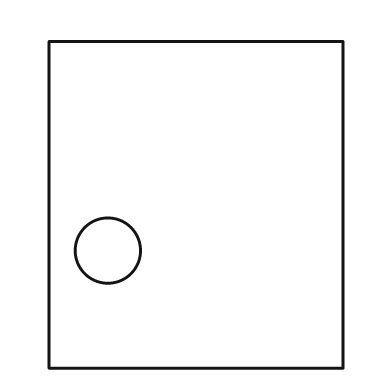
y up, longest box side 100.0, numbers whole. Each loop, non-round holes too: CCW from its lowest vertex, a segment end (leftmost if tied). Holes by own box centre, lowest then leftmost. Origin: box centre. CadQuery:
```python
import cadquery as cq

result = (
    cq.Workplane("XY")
    .moveTo(-45.0, -50.0)
    .lineTo(45.0, -50.0)
    .lineTo(45.0, 50.0)
    .lineTo(-45.0, 50.0)
    .close()
    .moveTo(-27.0, -14.0)
    .circle(10.0)
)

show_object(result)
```